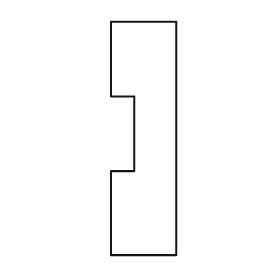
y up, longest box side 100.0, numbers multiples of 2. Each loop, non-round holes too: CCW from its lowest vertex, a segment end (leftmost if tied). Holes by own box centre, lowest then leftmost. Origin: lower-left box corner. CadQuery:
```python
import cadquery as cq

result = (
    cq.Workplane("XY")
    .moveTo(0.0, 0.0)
    .lineTo(28.0, 0.0)
    .lineTo(28.0, 100.0)
    .lineTo(0.0, 100.0)
    .lineTo(0.0, 68.0)
    .lineTo(10.0, 68.0)
    .lineTo(10.0, 36.0)
    .lineTo(0.0, 36.0)
    .close()
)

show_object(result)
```